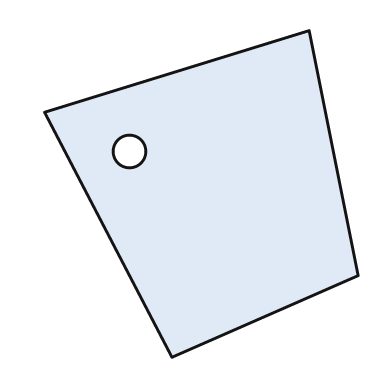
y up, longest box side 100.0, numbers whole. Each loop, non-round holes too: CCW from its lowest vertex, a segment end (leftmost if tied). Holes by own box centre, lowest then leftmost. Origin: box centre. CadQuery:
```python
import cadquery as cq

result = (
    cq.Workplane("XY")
    .moveTo(-9.0, -50.0)
    .lineTo(48.0, -25.0)
    .lineTo(33.0, 50.0)
    .lineTo(-48.0, 25.0)
    .close()
    .moveTo(-22.0, 13.0)
    .circle(5.0)
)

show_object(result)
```